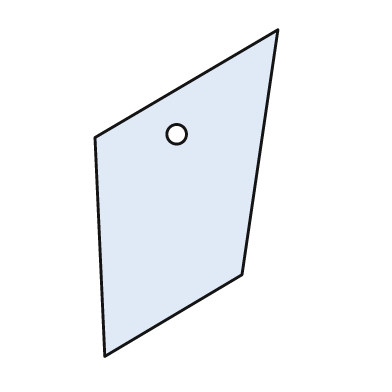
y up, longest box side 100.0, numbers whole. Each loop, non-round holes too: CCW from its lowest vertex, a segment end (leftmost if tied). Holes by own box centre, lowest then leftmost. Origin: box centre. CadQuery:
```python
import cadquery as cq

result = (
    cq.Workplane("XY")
    .moveTo(-25.0, -50.0)
    .lineTo(17.0, -25.0)
    .lineTo(28.0, 50.0)
    .lineTo(-28.0, 17.0)
    .close()
    .moveTo(-3.0, 18.0)
    .circle(3.0)
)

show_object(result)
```